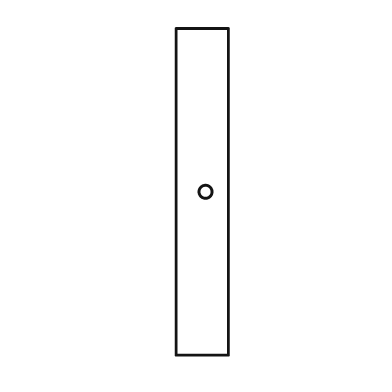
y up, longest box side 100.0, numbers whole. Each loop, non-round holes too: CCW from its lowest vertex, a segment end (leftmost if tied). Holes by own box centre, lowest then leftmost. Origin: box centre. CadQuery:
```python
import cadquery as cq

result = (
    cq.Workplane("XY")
    .moveTo(-8.0, -50.0)
    .lineTo(8.0, -50.0)
    .lineTo(8.0, 50.0)
    .lineTo(-8.0, 50.0)
    .close()
    .moveTo(1.0, 0.0)
    .circle(2.0)
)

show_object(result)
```